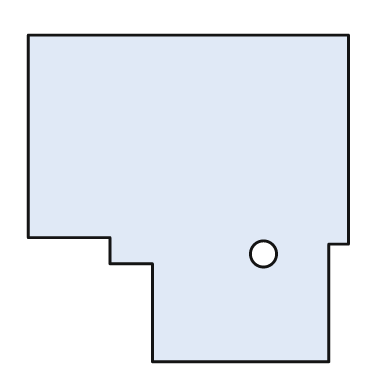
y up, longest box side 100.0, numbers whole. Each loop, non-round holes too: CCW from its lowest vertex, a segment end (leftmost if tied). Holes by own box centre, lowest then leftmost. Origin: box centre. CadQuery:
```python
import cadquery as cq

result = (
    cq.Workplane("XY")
    .moveTo(-11.0, -50.0)
    .lineTo(43.0, -50.0)
    .lineTo(43.0, -14.0)
    .lineTo(49.0, -14.0)
    .lineTo(49.0, 50.0)
    .lineTo(-49.0, 50.0)
    .lineTo(-49.0, -12.0)
    .lineTo(-24.0, -12.0)
    .lineTo(-24.0, -20.0)
    .lineTo(-11.0, -20.0)
    .close()
    .moveTo(23.0, -17.0)
    .circle(4.0)
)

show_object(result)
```